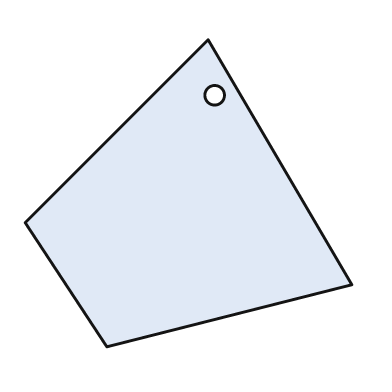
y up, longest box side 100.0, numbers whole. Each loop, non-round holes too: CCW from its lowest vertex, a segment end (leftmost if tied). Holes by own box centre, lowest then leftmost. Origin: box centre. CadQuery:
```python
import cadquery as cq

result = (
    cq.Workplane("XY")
    .moveTo(-25.0, -47.0)
    .lineTo(50.0, -28.0)
    .lineTo(6.0, 47.0)
    .lineTo(-50.0, -9.0)
    .close()
    .moveTo(8.0, 30.0)
    .circle(3.0)
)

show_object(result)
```